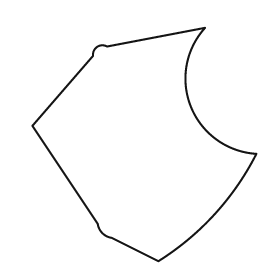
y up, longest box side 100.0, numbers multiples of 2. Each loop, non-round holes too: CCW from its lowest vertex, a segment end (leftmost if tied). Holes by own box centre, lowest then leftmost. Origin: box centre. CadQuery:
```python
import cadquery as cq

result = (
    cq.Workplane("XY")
    .moveTo(6.0, -50.0)
    .threePointArc((30.0, -30.0), (48.0, -4.0))
    .threePointArc((20.0, 16.0), (26.0, 50.0))
    .lineTo(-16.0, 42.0)
    .threePointArc((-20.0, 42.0), (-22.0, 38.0))
    .lineTo(-48.0, 8.0)
    .lineTo(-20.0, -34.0)
    .threePointArc((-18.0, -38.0), (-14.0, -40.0))
    .close()
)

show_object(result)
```